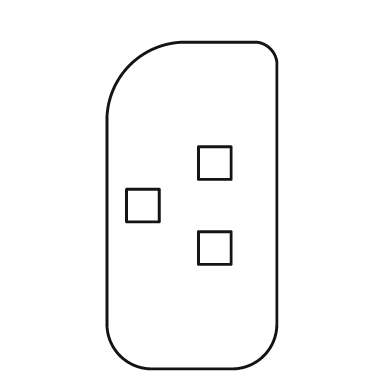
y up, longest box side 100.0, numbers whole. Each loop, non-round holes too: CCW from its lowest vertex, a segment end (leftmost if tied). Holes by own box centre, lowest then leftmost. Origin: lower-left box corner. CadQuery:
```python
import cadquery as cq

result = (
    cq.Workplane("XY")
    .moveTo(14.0, 0.0)
    .lineTo(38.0, 0.0)
    .threePointArc((48.0, 4.0), (52.0, 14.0))
    .lineTo(52.0, 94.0)
    .threePointArc((50.0, 98.0), (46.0, 100.0))
    .lineTo(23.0, 100.0)
    .threePointArc((7.0, 93.0), (0.0, 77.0))
    .lineTo(0.0, 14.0)
    .threePointArc((4.0, 4.0), (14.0, 0.0))
    .close()
    .moveTo(28.0, 32.0)
    .lineTo(38.0, 32.0)
    .lineTo(38.0, 42.0)
    .lineTo(28.0, 42.0)
    .close()
    .moveTo(6.0, 45.0)
    .lineTo(16.0, 45.0)
    .lineTo(16.0, 55.0)
    .lineTo(6.0, 55.0)
    .close()
    .moveTo(28.0, 58.0)
    .lineTo(38.0, 58.0)
    .lineTo(38.0, 68.0)
    .lineTo(28.0, 68.0)
    .close()
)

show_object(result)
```